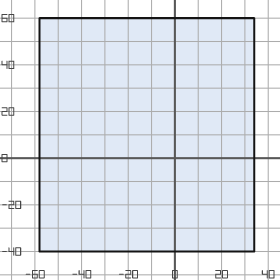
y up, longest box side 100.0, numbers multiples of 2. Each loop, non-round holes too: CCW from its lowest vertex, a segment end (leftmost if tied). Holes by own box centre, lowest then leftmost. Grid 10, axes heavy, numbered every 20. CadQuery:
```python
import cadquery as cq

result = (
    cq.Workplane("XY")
    .moveTo(-58.0, -40.0)
    .lineTo(34.0, -40.0)
    .lineTo(34.0, 60.0)
    .lineTo(-58.0, 60.0)
    .close()
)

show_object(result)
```